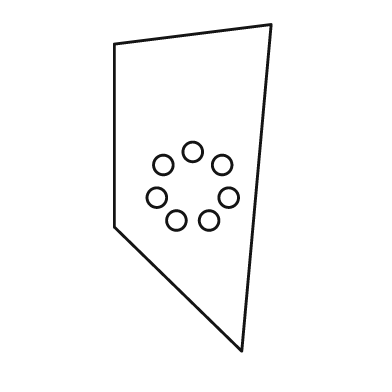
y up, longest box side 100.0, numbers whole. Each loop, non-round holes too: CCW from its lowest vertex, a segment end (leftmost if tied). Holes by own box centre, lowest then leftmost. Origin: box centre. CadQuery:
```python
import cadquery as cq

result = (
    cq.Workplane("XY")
    .moveTo(15.0, -50.0)
    .lineTo(24.0, 50.0)
    .lineTo(-24.0, 44.0)
    .lineTo(-24.0, -12.0)
    .close()
    .moveTo(-5.0, -10.0)
    .circle(3.0)
    .moveTo(5.0, -10.0)
    .circle(3.0)
    .moveTo(-11.0, -3.0)
    .circle(3.0)
    .moveTo(11.0, -3.0)
    .circle(3.0)
    .moveTo(-9.0, 7.0)
    .circle(3.0)
    .moveTo(9.0, 7.0)
    .circle(3.0)
    .moveTo(0.0, 11.0)
    .circle(3.0)
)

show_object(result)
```